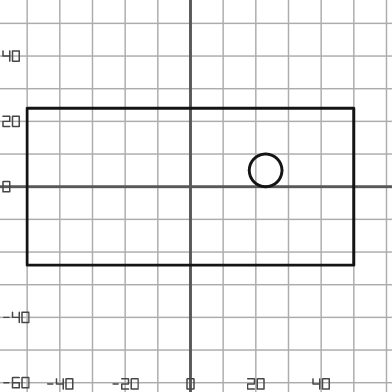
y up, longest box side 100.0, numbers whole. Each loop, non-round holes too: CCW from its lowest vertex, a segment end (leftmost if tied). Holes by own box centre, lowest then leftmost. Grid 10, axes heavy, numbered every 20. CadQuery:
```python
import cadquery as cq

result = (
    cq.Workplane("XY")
    .moveTo(-50.0, -24.0)
    .lineTo(50.0, -24.0)
    .lineTo(50.0, 24.0)
    .lineTo(-50.0, 24.0)
    .close()
    .moveTo(23.0, 5.0)
    .circle(5.0)
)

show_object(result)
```